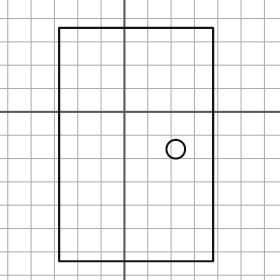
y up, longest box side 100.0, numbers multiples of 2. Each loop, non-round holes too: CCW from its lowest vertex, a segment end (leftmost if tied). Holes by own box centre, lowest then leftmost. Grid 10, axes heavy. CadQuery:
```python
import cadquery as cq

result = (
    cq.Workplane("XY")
    .moveTo(-28.0, -64.0)
    .lineTo(38.0, -64.0)
    .lineTo(38.0, 36.0)
    .lineTo(-28.0, 36.0)
    .close()
    .moveTo(22.0, -16.0)
    .circle(4.0)
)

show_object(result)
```